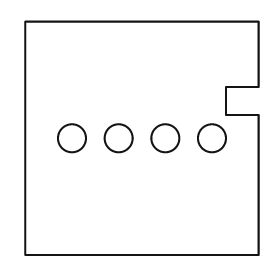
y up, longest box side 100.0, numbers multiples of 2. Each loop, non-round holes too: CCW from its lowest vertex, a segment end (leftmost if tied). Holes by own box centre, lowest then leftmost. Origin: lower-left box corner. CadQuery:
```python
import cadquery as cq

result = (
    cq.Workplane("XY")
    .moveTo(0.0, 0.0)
    .lineTo(100.0, 0.0)
    .lineTo(100.0, 60.0)
    .lineTo(86.0, 60.0)
    .lineTo(86.0, 72.0)
    .lineTo(100.0, 72.0)
    .lineTo(100.0, 100.0)
    .lineTo(0.0, 100.0)
    .close()
    .moveTo(20.0, 50.0)
    .circle(6.0)
    .moveTo(40.0, 50.0)
    .circle(6.0)
    .moveTo(60.0, 50.0)
    .circle(6.0)
    .moveTo(80.0, 50.0)
    .circle(6.0)
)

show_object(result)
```